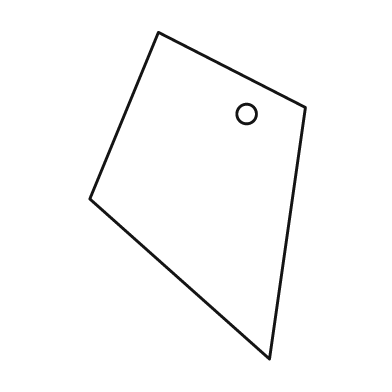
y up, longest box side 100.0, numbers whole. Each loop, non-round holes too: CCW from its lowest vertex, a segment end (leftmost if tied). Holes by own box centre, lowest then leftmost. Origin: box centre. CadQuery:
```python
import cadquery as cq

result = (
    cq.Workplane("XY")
    .moveTo(22.0, -50.0)
    .lineTo(33.0, 27.0)
    .lineTo(-12.0, 50.0)
    .lineTo(-33.0, -1.0)
    .close()
    .moveTo(15.0, 25.0)
    .circle(3.0)
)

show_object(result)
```